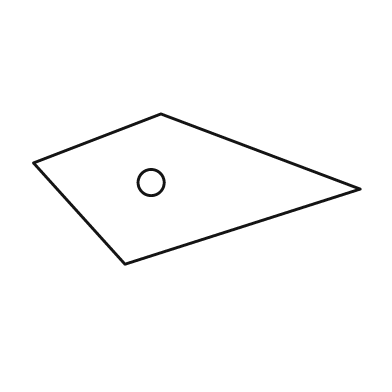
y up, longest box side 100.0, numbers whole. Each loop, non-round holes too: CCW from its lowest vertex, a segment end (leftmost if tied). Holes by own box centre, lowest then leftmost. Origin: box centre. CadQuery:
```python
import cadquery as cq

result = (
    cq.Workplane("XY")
    .moveTo(-22.0, -23.0)
    .lineTo(50.0, 0.0)
    .lineTo(-11.0, 23.0)
    .lineTo(-50.0, 8.0)
    .close()
    .moveTo(-14.0, 2.0)
    .circle(4.0)
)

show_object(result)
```